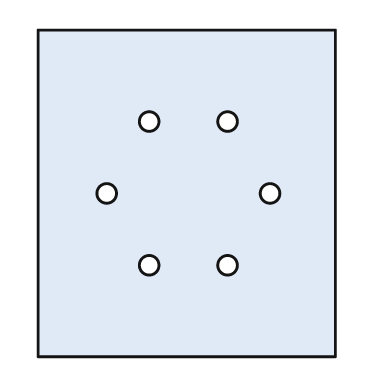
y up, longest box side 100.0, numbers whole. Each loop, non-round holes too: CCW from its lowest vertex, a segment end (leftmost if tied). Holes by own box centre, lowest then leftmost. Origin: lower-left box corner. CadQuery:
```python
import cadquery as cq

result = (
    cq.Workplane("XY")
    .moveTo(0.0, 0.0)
    .lineTo(91.0, 0.0)
    .lineTo(91.0, 100.0)
    .lineTo(0.0, 100.0)
    .close()
    .moveTo(34.0, 28.0)
    .circle(3.0)
    .moveTo(58.0, 28.0)
    .circle(3.0)
    .moveTo(21.0, 50.0)
    .circle(3.0)
    .moveTo(71.0, 50.0)
    .circle(3.0)
    .moveTo(34.0, 72.0)
    .circle(3.0)
    .moveTo(58.0, 72.0)
    .circle(3.0)
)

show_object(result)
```